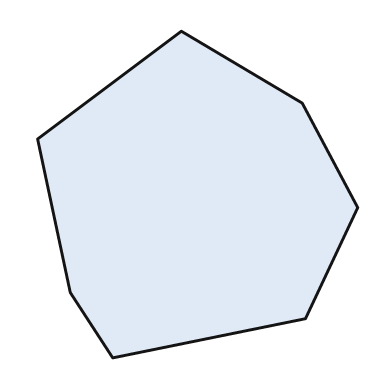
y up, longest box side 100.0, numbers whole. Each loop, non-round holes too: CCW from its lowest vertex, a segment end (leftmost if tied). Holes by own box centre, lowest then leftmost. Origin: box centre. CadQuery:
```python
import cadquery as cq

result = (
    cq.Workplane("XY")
    .moveTo(-26.0, -50.0)
    .lineTo(33.0, -38.0)
    .lineTo(49.0, -4.0)
    .lineTo(32.0, 28.0)
    .lineTo(-5.0, 50.0)
    .lineTo(-49.0, 17.0)
    .lineTo(-39.0, -30.0)
    .close()
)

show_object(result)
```